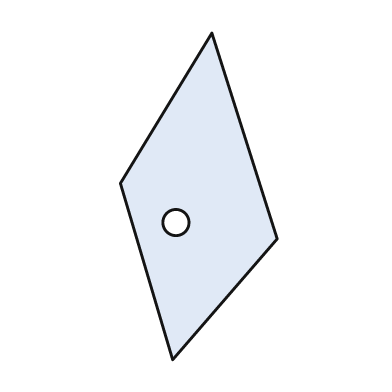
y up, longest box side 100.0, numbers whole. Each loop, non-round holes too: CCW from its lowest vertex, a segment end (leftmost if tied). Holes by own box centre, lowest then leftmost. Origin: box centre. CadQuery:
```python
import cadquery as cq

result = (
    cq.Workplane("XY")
    .moveTo(-8.0, -50.0)
    .lineTo(24.0, -13.0)
    .lineTo(4.0, 50.0)
    .lineTo(-24.0, 4.0)
    .close()
    .moveTo(-7.0, -8.0)
    .circle(4.0)
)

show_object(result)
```